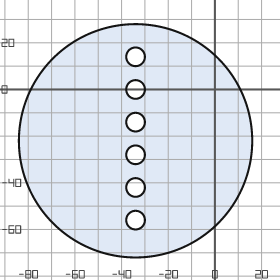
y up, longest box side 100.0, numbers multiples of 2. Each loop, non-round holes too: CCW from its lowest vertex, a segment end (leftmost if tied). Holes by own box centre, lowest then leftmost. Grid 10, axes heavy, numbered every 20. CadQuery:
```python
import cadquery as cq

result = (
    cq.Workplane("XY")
    .moveTo(-34.0, -22.0)
    .circle(50.0)
    .moveTo(-34.0, -56.0)
    .circle(4.0)
    .moveTo(-34.0, -42.0)
    .circle(4.0)
    .moveTo(-34.0, -28.0)
    .circle(4.0)
    .moveTo(-34.0, -14.0)
    .circle(4.0)
    .moveTo(-34.0, 0.0)
    .circle(4.0)
    .moveTo(-34.0, 14.0)
    .circle(4.0)
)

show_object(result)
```